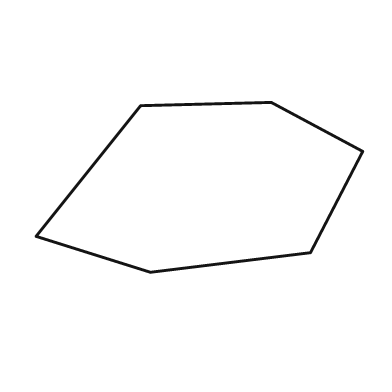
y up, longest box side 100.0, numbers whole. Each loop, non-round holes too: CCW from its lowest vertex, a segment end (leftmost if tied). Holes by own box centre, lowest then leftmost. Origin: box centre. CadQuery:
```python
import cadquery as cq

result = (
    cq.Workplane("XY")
    .moveTo(-15.0, -26.0)
    .lineTo(34.0, -20.0)
    .lineTo(50.0, 11.0)
    .lineTo(22.0, 26.0)
    .lineTo(-18.0, 25.0)
    .lineTo(-50.0, -15.0)
    .close()
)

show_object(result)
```